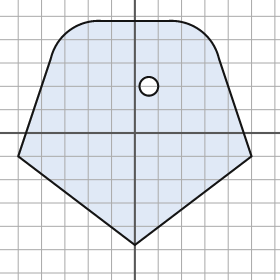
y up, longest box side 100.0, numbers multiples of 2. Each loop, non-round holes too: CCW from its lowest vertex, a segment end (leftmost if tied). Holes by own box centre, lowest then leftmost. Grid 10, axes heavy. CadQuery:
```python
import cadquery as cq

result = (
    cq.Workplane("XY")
    .moveTo(0.0, -48.0)
    .lineTo(50.0, -10.0)
    .lineTo(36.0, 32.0)
    .threePointArc((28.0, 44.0), (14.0, 48.0))
    .lineTo(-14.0, 48.0)
    .threePointArc((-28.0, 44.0), (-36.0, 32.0))
    .lineTo(-50.0, -10.0)
    .close()
    .moveTo(6.0, 20.0)
    .circle(4.0)
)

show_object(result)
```